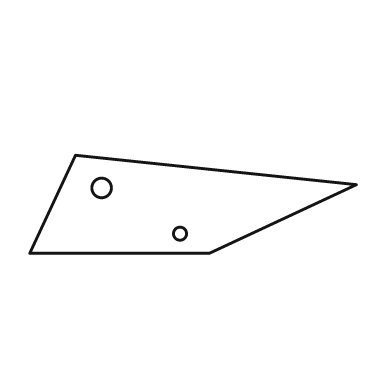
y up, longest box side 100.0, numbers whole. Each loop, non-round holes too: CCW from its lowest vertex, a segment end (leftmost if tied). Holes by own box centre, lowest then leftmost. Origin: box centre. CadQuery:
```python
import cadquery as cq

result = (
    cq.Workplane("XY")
    .moveTo(-50.0, -15.0)
    .lineTo(5.0, -15.0)
    .lineTo(50.0, 6.0)
    .lineTo(-36.0, 15.0)
    .close()
    .moveTo(-4.0, -9.0)
    .circle(2.0)
    .moveTo(-28.0, 5.0)
    .circle(3.0)
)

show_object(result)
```